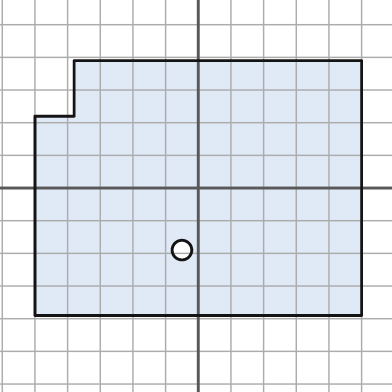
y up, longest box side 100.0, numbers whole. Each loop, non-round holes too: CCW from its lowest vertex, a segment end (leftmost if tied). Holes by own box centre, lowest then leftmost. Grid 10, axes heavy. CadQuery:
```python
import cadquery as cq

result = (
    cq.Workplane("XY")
    .moveTo(-50.0, -39.0)
    .lineTo(50.0, -39.0)
    .lineTo(50.0, 39.0)
    .lineTo(-38.0, 39.0)
    .lineTo(-38.0, 22.0)
    .lineTo(-50.0, 22.0)
    .close()
    .moveTo(-5.0, -19.0)
    .circle(3.0)
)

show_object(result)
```